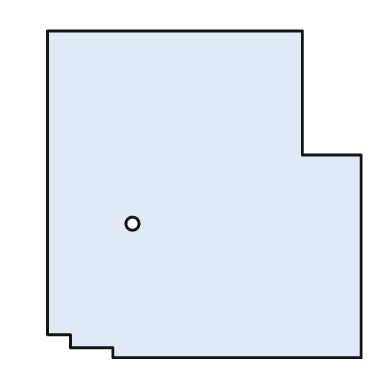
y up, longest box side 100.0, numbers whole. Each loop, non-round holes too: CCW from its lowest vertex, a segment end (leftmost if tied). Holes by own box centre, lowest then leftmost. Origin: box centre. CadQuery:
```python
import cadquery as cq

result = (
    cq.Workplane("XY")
    .moveTo(-28.0, -50.0)
    .lineTo(48.0, -50.0)
    .lineTo(48.0, 12.0)
    .lineTo(30.0, 12.0)
    .lineTo(30.0, 50.0)
    .lineTo(-48.0, 50.0)
    .lineTo(-48.0, -43.0)
    .lineTo(-41.0, -43.0)
    .lineTo(-41.0, -47.0)
    .lineTo(-28.0, -47.0)
    .close()
    .moveTo(-22.0, -9.0)
    .circle(2.0)
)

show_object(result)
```